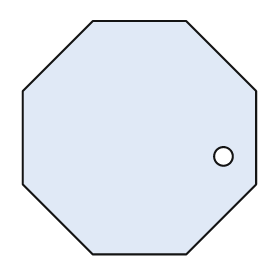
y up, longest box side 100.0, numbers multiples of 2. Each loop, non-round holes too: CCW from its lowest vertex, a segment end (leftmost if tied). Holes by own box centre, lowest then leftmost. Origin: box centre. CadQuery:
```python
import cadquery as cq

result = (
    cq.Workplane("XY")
    .moveTo(-20.0, -50.0)
    .lineTo(20.0, -50.0)
    .lineTo(50.0, -20.0)
    .lineTo(50.0, 20.0)
    .lineTo(20.0, 50.0)
    .lineTo(-20.0, 50.0)
    .lineTo(-50.0, 20.0)
    .lineTo(-50.0, -20.0)
    .close()
    .moveTo(36.0, -8.0)
    .circle(4.0)
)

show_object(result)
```